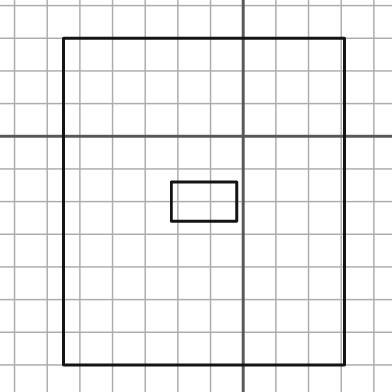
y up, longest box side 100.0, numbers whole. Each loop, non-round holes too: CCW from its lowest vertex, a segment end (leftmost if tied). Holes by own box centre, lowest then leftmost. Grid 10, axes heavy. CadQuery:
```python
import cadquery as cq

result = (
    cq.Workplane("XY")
    .moveTo(-55.0, -70.0)
    .lineTo(31.0, -70.0)
    .lineTo(31.0, 30.0)
    .lineTo(-55.0, 30.0)
    .close()
    .moveTo(-22.0, -26.0)
    .lineTo(-2.0, -26.0)
    .lineTo(-2.0, -14.0)
    .lineTo(-22.0, -14.0)
    .close()
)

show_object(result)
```